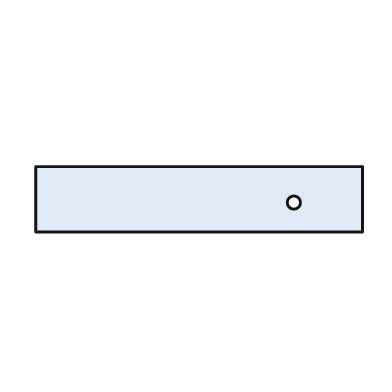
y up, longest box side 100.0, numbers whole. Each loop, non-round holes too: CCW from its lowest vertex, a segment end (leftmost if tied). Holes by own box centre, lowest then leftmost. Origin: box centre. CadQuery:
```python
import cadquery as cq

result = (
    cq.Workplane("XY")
    .moveTo(-50.0, -10.0)
    .lineTo(50.0, -10.0)
    .lineTo(50.0, 10.0)
    .lineTo(-50.0, 10.0)
    .close()
    .moveTo(29.0, -1.0)
    .circle(2.0)
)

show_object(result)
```